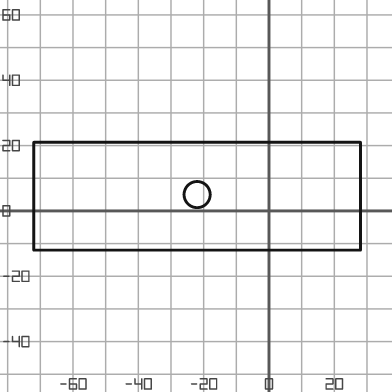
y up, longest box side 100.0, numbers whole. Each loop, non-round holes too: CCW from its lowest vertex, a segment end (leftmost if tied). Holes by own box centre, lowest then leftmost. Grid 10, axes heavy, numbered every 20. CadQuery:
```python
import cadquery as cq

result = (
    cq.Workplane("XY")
    .moveTo(-72.0, -12.0)
    .lineTo(28.0, -12.0)
    .lineTo(28.0, 21.0)
    .lineTo(-72.0, 21.0)
    .close()
    .moveTo(-22.0, 5.0)
    .circle(4.0)
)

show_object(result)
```